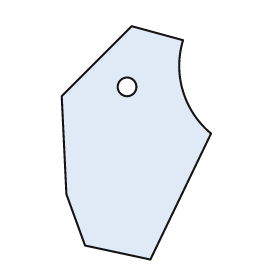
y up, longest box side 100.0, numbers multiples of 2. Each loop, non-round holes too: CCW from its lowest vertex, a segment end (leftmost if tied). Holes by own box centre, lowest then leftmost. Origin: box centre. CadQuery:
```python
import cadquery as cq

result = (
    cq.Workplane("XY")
    .moveTo(6.0, -50.0)
    .lineTo(32.0, 4.0)
    .threePointArc((20.0, 22.0), (20.0, 44.0))
    .lineTo(-2.0, 50.0)
    .lineTo(-32.0, 20.0)
    .lineTo(-30.0, -22.0)
    .lineTo(-22.0, -44.0)
    .close()
    .moveTo(-4.0, 24.0)
    .circle(4.0)
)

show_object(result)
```